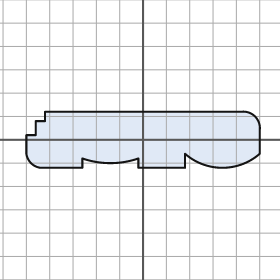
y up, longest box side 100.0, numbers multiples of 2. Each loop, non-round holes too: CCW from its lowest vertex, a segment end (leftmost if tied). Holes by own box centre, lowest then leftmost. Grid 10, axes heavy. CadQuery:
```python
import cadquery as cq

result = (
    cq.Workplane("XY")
    .moveTo(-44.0, -12.0)
    .lineTo(-26.0, -12.0)
    .lineTo(-26.0, -8.0)
    .threePointArc((-14.0, -10.0), (-2.0, -8.0))
    .lineTo(-2.0, -12.0)
    .lineTo(18.0, -12.0)
    .lineTo(18.0, -6.0)
    .threePointArc((34.0, -12.0), (50.0, -6.0))
    .lineTo(50.0, 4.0)
    .threePointArc((48.0, 10.0), (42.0, 12.0))
    .lineTo(-42.0, 12.0)
    .lineTo(-42.0, 8.0)
    .lineTo(-46.0, 8.0)
    .lineTo(-46.0, 2.0)
    .lineTo(-50.0, 2.0)
    .lineTo(-50.0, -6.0)
    .threePointArc((-48.0, -10.0), (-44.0, -12.0))
    .close()
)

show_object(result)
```